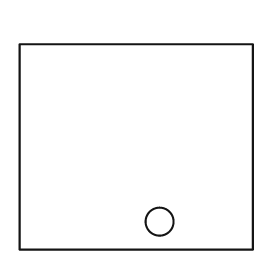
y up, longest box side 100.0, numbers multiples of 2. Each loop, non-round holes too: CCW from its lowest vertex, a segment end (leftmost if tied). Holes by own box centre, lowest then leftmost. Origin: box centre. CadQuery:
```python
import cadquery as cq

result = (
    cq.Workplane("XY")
    .moveTo(-50.0, -44.0)
    .lineTo(50.0, -44.0)
    .lineTo(50.0, 44.0)
    .lineTo(-50.0, 44.0)
    .close()
    .moveTo(10.0, -32.0)
    .circle(6.0)
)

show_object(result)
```